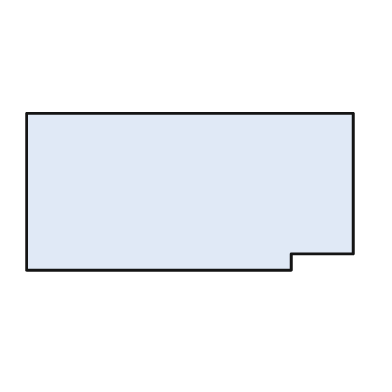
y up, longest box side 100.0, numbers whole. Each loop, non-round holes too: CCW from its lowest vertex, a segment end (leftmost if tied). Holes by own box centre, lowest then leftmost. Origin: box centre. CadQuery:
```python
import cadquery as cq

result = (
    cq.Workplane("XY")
    .moveTo(-50.0, -24.0)
    .lineTo(31.0, -24.0)
    .lineTo(31.0, -19.0)
    .lineTo(50.0, -19.0)
    .lineTo(50.0, 24.0)
    .lineTo(-50.0, 24.0)
    .close()
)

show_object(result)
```